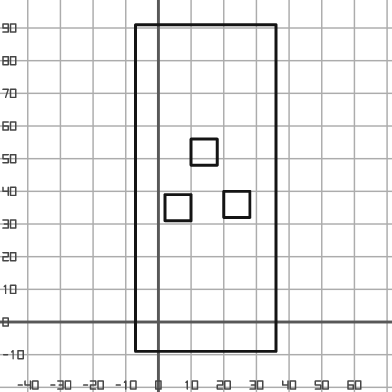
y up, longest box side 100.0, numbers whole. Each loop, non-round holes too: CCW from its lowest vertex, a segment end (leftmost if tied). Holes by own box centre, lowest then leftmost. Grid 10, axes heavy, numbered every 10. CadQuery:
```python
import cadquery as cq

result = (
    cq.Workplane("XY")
    .moveTo(-7.0, -9.0)
    .lineTo(36.0, -9.0)
    .lineTo(36.0, 91.0)
    .lineTo(-7.0, 91.0)
    .close()
    .moveTo(2.0, 31.0)
    .lineTo(10.0, 31.0)
    .lineTo(10.0, 39.0)
    .lineTo(2.0, 39.0)
    .close()
    .moveTo(20.0, 32.0)
    .lineTo(28.0, 32.0)
    .lineTo(28.0, 40.0)
    .lineTo(20.0, 40.0)
    .close()
    .moveTo(10.0, 48.0)
    .lineTo(18.0, 48.0)
    .lineTo(18.0, 56.0)
    .lineTo(10.0, 56.0)
    .close()
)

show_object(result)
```